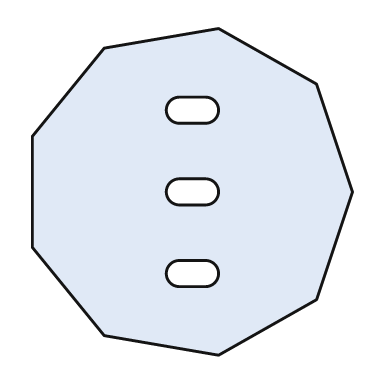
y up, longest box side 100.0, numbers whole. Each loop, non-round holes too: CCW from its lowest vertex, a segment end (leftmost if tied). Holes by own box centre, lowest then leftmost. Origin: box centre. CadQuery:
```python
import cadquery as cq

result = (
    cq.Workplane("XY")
    .moveTo(8.0, -50.0)
    .lineTo(38.0, -33.0)
    .lineTo(49.0, 0.0)
    .lineTo(38.0, 33.0)
    .lineTo(8.0, 50.0)
    .lineTo(-27.0, 44.0)
    .lineTo(-49.0, 17.0)
    .lineTo(-49.0, -17.0)
    .lineTo(-27.0, -44.0)
    .close()
    .moveTo(-4.0, -29.0)
    .lineTo(4.0, -29.0)
    .threePointArc((8.0, -25.0), (4.0, -21.0))
    .lineTo(-4.0, -21.0)
    .threePointArc((-8.0, -25.0), (-4.0, -29.0))
    .close()
    .moveTo(-4.0, -4.0)
    .lineTo(4.0, -4.0)
    .threePointArc((8.0, 0.0), (4.0, 4.0))
    .lineTo(-4.0, 4.0)
    .threePointArc((-8.0, 0.0), (-4.0, -4.0))
    .close()
    .moveTo(-4.0, 21.0)
    .lineTo(4.0, 21.0)
    .threePointArc((8.0, 25.0), (4.0, 29.0))
    .lineTo(-4.0, 29.0)
    .threePointArc((-8.0, 25.0), (-4.0, 21.0))
    .close()
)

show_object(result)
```